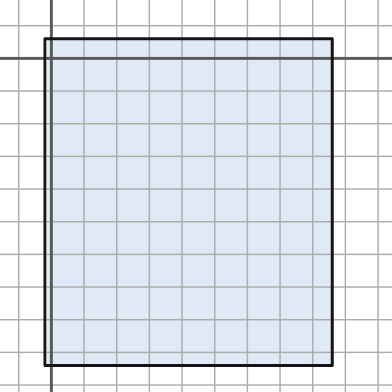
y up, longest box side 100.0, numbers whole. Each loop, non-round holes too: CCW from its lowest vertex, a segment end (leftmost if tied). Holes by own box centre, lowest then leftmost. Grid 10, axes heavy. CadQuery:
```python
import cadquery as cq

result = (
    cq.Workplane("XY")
    .moveTo(-2.0, -94.0)
    .lineTo(86.0, -94.0)
    .lineTo(86.0, 6.0)
    .lineTo(-2.0, 6.0)
    .close()
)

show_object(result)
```